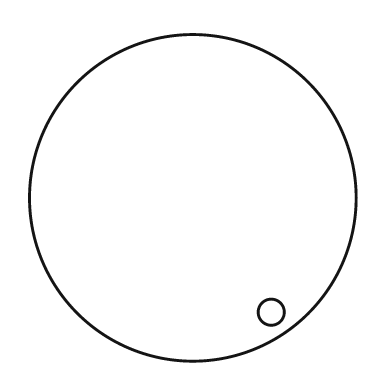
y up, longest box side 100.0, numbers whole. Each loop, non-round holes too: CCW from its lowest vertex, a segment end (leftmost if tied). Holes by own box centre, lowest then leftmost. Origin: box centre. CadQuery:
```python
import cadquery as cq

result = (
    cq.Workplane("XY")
    .moveTo(0.0, 0.0)
    .circle(50.0)
    .moveTo(24.0, -35.0)
    .circle(4.0)
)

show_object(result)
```